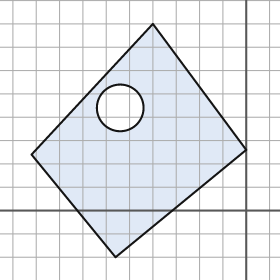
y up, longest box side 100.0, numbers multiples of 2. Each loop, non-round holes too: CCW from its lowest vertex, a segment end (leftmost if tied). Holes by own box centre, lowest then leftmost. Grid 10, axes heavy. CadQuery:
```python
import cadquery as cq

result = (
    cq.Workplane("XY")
    .moveTo(-56.0, -20.0)
    .lineTo(0.0, 26.0)
    .lineTo(-40.0, 80.0)
    .lineTo(-92.0, 24.0)
    .close()
    .moveTo(-54.0, 44.0)
    .circle(10.0)
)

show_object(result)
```